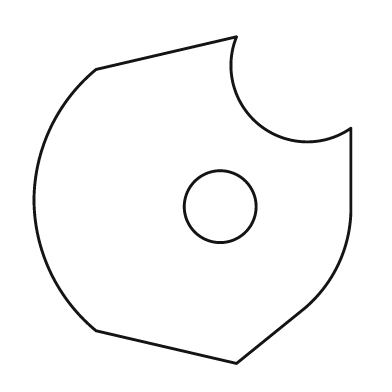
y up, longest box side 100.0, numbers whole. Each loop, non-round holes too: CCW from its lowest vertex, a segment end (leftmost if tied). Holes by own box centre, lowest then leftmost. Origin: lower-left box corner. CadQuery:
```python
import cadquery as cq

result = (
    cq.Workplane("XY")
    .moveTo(62.0, 0.0)
    .lineTo(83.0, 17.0)
    .threePointArc((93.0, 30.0), (97.0, 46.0))
    .lineTo(97.0, 72.0)
    .threePointArc((69.0, 73.0), (62.0, 100.0))
    .lineTo(19.0, 90.0)
    .threePointArc((5.0, 72.0), (0.0, 50.0))
    .threePointArc((5.0, 28.0), (19.0, 10.0))
    .close()
    .moveTo(57.0, 48.0)
    .circle(11.0)
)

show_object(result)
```